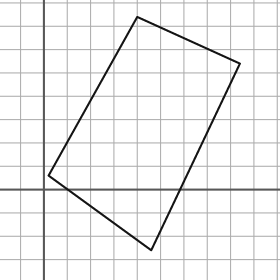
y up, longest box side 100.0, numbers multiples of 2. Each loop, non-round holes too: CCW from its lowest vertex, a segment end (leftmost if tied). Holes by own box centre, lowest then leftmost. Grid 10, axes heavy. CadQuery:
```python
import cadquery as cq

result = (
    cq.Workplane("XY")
    .moveTo(46.0, -26.0)
    .lineTo(84.0, 54.0)
    .lineTo(40.0, 74.0)
    .lineTo(2.0, 6.0)
    .close()
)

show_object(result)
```